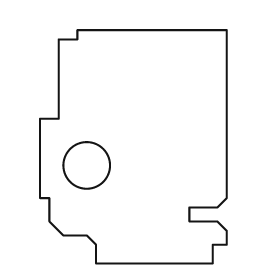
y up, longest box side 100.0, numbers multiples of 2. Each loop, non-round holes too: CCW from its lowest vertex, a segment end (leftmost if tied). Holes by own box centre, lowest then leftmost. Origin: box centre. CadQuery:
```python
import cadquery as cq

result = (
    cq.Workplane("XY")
    .moveTo(-16.0, -50.0)
    .lineTo(34.0, -50.0)
    .lineTo(34.0, -42.0)
    .lineTo(40.0, -42.0)
    .lineTo(40.0, -36.0)
    .lineTo(36.0, -32.0)
    .lineTo(24.0, -32.0)
    .lineTo(24.0, -26.0)
    .lineTo(36.0, -26.0)
    .lineTo(40.0, -22.0)
    .lineTo(40.0, 50.0)
    .lineTo(-24.0, 50.0)
    .lineTo(-24.0, 46.0)
    .lineTo(-32.0, 46.0)
    .lineTo(-32.0, 12.0)
    .lineTo(-40.0, 12.0)
    .lineTo(-40.0, -22.0)
    .lineTo(-36.0, -22.0)
    .lineTo(-36.0, -32.0)
    .lineTo(-30.0, -38.0)
    .lineTo(-20.0, -38.0)
    .lineTo(-16.0, -42.0)
    .close()
    .moveTo(-20.0, -8.0)
    .circle(10.0)
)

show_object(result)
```